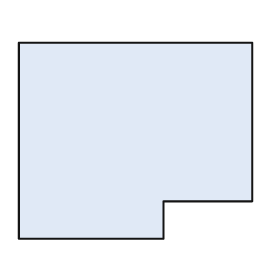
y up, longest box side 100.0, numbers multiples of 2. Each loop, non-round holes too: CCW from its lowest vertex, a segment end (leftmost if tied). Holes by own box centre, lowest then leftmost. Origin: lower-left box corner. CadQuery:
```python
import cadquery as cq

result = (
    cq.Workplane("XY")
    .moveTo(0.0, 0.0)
    .lineTo(62.0, 0.0)
    .lineTo(62.0, 16.0)
    .lineTo(100.0, 16.0)
    .lineTo(100.0, 84.0)
    .lineTo(0.0, 84.0)
    .close()
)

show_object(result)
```